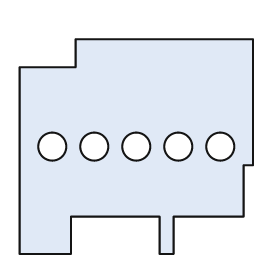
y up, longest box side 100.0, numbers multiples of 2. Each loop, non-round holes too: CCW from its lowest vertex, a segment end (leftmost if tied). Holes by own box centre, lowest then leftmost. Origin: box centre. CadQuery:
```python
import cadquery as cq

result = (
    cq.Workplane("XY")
    .moveTo(-50.0, -46.0)
    .lineTo(-28.0, -46.0)
    .lineTo(-28.0, -30.0)
    .lineTo(10.0, -30.0)
    .lineTo(10.0, -46.0)
    .lineTo(16.0, -46.0)
    .lineTo(16.0, -30.0)
    .lineTo(46.0, -30.0)
    .lineTo(46.0, -8.0)
    .lineTo(50.0, -8.0)
    .lineTo(50.0, 46.0)
    .lineTo(-26.0, 46.0)
    .lineTo(-26.0, 34.0)
    .lineTo(-50.0, 34.0)
    .close()
    .moveTo(-36.0, 0.0)
    .circle(6.0)
    .moveTo(-18.0, 0.0)
    .circle(6.0)
    .moveTo(0.0, 0.0)
    .circle(6.0)
    .moveTo(18.0, 0.0)
    .circle(6.0)
    .moveTo(36.0, 0.0)
    .circle(6.0)
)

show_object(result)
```